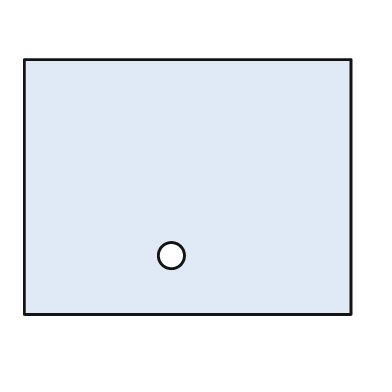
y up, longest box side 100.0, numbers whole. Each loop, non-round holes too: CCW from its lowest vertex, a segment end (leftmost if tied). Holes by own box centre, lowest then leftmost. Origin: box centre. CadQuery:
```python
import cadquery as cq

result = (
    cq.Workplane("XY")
    .moveTo(-50.0, -39.0)
    .lineTo(50.0, -39.0)
    .lineTo(50.0, 39.0)
    .lineTo(-50.0, 39.0)
    .close()
    .moveTo(-5.0, -21.0)
    .circle(4.0)
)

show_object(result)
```